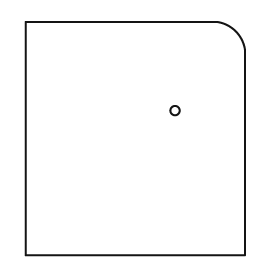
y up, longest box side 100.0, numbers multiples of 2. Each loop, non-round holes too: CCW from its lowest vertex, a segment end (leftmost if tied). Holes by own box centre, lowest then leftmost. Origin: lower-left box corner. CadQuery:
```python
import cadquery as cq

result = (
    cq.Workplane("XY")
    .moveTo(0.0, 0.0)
    .lineTo(94.0, 0.0)
    .lineTo(94.0, 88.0)
    .threePointArc((90.0, 96.0), (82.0, 100.0))
    .lineTo(0.0, 100.0)
    .close()
    .moveTo(64.0, 62.0)
    .circle(2.0)
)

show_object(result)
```